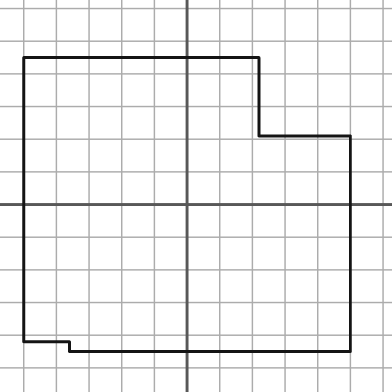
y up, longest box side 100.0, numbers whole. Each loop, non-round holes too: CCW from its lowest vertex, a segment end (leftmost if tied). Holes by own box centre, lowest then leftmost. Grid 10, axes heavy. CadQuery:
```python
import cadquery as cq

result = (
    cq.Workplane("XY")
    .moveTo(-36.0, -45.0)
    .lineTo(50.0, -45.0)
    .lineTo(50.0, 21.0)
    .lineTo(22.0, 21.0)
    .lineTo(22.0, 45.0)
    .lineTo(-50.0, 45.0)
    .lineTo(-50.0, -42.0)
    .lineTo(-36.0, -42.0)
    .close()
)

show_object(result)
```